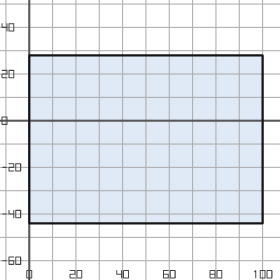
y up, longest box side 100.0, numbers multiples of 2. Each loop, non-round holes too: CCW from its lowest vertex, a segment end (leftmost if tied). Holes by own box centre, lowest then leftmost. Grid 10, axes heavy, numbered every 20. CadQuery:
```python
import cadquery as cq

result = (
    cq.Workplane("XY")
    .moveTo(0.0, -44.0)
    .lineTo(100.0, -44.0)
    .lineTo(100.0, 28.0)
    .lineTo(0.0, 28.0)
    .close()
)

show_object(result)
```